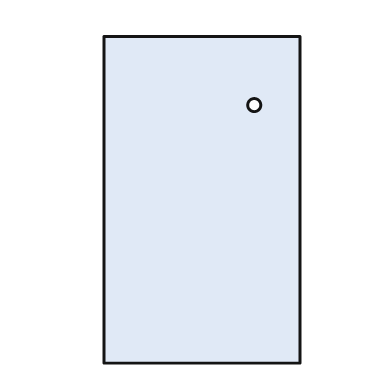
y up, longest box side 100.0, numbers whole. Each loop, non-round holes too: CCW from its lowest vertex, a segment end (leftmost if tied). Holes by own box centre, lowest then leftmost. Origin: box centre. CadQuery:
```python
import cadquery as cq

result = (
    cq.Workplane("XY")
    .moveTo(-30.0, -50.0)
    .lineTo(30.0, -50.0)
    .lineTo(30.0, 50.0)
    .lineTo(-30.0, 50.0)
    .close()
    .moveTo(16.0, 29.0)
    .circle(2.0)
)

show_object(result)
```